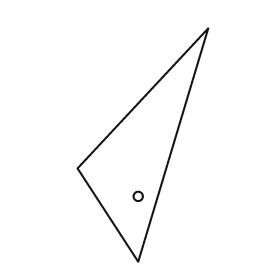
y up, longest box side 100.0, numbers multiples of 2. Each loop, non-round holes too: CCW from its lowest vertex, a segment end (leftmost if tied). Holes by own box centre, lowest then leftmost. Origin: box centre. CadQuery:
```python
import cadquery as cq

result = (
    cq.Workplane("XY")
    .moveTo(-2.0, -50.0)
    .lineTo(28.0, 50.0)
    .lineTo(-28.0, -10.0)
    .close()
    .moveTo(-2.0, -22.0)
    .circle(2.0)
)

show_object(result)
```